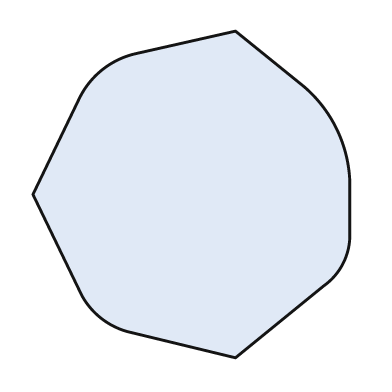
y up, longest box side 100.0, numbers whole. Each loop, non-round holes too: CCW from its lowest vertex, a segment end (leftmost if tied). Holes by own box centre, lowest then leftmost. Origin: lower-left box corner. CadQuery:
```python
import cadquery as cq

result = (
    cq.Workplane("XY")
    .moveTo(62.0, 0.0)
    .lineTo(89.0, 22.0)
    .threePointArc((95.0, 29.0), (97.0, 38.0))
    .lineTo(97.0, 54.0)
    .threePointArc((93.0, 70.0), (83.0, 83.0))
    .lineTo(62.0, 100.0)
    .lineTo(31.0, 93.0)
    .threePointArc((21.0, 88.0), (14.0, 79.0))
    .lineTo(0.0, 50.0)
    .lineTo(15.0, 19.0)
    .threePointArc((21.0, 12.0), (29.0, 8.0))
    .close()
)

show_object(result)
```